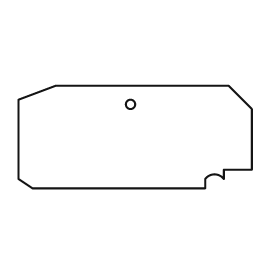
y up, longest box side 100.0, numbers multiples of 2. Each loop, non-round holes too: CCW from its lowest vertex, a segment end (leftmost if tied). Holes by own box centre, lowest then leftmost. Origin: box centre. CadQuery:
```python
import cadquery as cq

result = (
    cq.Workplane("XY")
    .moveTo(-44.0, -22.0)
    .lineTo(30.0, -22.0)
    .lineTo(30.0, -18.0)
    .threePointArc((34.0, -16.0), (38.0, -18.0))
    .lineTo(38.0, -14.0)
    .lineTo(50.0, -14.0)
    .lineTo(50.0, 12.0)
    .lineTo(40.0, 22.0)
    .lineTo(-34.0, 22.0)
    .lineTo(-50.0, 16.0)
    .lineTo(-50.0, -18.0)
    .close()
    .moveTo(-2.0, 14.0)
    .circle(2.0)
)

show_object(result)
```